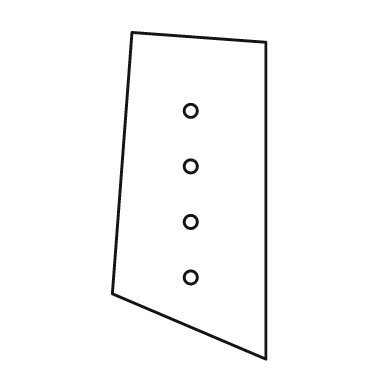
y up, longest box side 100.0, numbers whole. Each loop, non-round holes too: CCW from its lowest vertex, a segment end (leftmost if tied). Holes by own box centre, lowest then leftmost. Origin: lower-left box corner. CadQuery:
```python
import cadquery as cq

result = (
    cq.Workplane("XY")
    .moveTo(47.0, 0.0)
    .lineTo(47.0, 97.0)
    .lineTo(6.0, 100.0)
    .lineTo(0.0, 20.0)
    .close()
    .moveTo(24.0, 25.0)
    .circle(2.0)
    .moveTo(24.0, 42.0)
    .circle(2.0)
    .moveTo(24.0, 59.0)
    .circle(2.0)
    .moveTo(24.0, 76.0)
    .circle(2.0)
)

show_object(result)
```